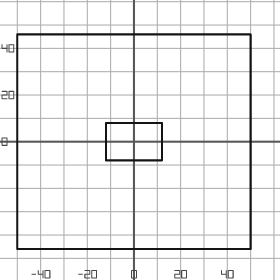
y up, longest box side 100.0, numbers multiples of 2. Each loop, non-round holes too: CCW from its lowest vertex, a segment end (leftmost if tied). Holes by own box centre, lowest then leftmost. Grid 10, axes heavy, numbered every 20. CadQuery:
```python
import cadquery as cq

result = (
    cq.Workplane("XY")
    .moveTo(-50.0, -46.0)
    .lineTo(50.0, -46.0)
    .lineTo(50.0, 46.0)
    .lineTo(-50.0, 46.0)
    .close()
    .moveTo(-12.0, -8.0)
    .lineTo(12.0, -8.0)
    .lineTo(12.0, 8.0)
    .lineTo(-12.0, 8.0)
    .close()
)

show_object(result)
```